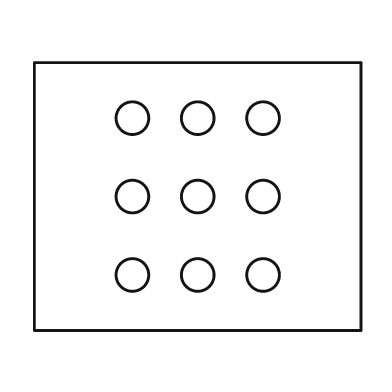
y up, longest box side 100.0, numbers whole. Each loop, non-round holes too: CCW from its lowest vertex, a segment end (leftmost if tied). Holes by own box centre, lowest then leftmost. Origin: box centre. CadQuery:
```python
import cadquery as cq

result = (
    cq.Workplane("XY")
    .moveTo(-50.0, -41.0)
    .lineTo(50.0, -41.0)
    .lineTo(50.0, 41.0)
    .lineTo(-50.0, 41.0)
    .close()
    .moveTo(-20.0, -24.0)
    .circle(5.0)
    .moveTo(0.0, -24.0)
    .circle(5.0)
    .moveTo(20.0, -24.0)
    .circle(5.0)
    .moveTo(-20.0, 0.0)
    .circle(5.0)
    .moveTo(0.0, 0.0)
    .circle(5.0)
    .moveTo(20.0, 0.0)
    .circle(5.0)
    .moveTo(-20.0, 24.0)
    .circle(5.0)
    .moveTo(0.0, 24.0)
    .circle(5.0)
    .moveTo(20.0, 24.0)
    .circle(5.0)
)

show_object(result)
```